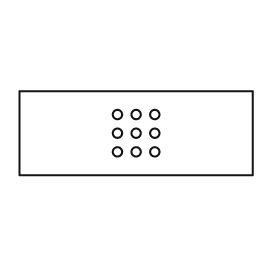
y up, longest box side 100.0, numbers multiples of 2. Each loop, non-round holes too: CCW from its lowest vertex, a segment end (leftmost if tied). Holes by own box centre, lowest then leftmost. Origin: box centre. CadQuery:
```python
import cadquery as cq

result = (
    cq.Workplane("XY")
    .moveTo(-50.0, -18.0)
    .lineTo(50.0, -18.0)
    .lineTo(50.0, 18.0)
    .lineTo(-50.0, 18.0)
    .close()
    .moveTo(-8.0, -8.0)
    .circle(2.0)
    .moveTo(0.0, -8.0)
    .circle(2.0)
    .moveTo(8.0, -8.0)
    .circle(2.0)
    .moveTo(-8.0, 0.0)
    .circle(2.0)
    .moveTo(0.0, 0.0)
    .circle(2.0)
    .moveTo(8.0, 0.0)
    .circle(2.0)
    .moveTo(-8.0, 8.0)
    .circle(2.0)
    .moveTo(0.0, 8.0)
    .circle(2.0)
    .moveTo(8.0, 8.0)
    .circle(2.0)
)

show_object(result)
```